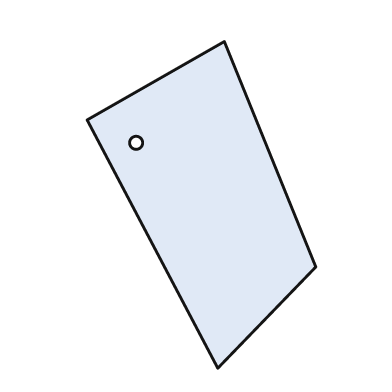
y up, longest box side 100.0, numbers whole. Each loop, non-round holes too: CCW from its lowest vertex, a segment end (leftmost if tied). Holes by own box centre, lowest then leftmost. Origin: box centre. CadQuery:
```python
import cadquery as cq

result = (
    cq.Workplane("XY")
    .moveTo(5.0, -50.0)
    .lineTo(35.0, -19.0)
    .lineTo(7.0, 50.0)
    .lineTo(-35.0, 26.0)
    .close()
    .moveTo(-20.0, 19.0)
    .circle(2.0)
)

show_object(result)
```